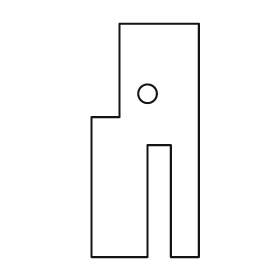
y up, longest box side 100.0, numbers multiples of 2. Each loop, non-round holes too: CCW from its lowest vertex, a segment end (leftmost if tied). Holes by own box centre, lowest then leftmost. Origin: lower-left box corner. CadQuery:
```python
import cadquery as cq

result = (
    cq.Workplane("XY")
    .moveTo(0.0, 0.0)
    .lineTo(24.0, 0.0)
    .lineTo(24.0, 48.0)
    .lineTo(34.0, 48.0)
    .lineTo(34.0, 0.0)
    .lineTo(46.0, 0.0)
    .lineTo(46.0, 100.0)
    .lineTo(12.0, 100.0)
    .lineTo(12.0, 60.0)
    .lineTo(0.0, 60.0)
    .close()
    .moveTo(24.0, 70.0)
    .circle(4.0)
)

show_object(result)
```